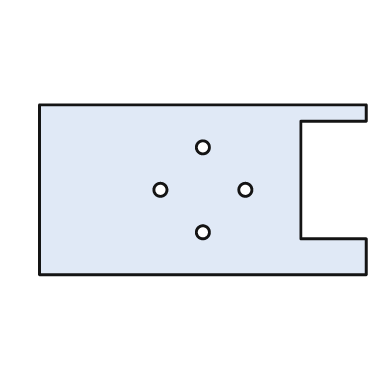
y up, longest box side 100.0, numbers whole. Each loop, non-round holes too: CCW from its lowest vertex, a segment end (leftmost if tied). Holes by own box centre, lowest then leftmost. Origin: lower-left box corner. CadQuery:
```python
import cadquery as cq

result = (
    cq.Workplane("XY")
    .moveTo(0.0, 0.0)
    .lineTo(100.0, 0.0)
    .lineTo(100.0, 11.0)
    .lineTo(80.0, 11.0)
    .lineTo(80.0, 47.0)
    .lineTo(100.0, 47.0)
    .lineTo(100.0, 52.0)
    .lineTo(0.0, 52.0)
    .close()
    .moveTo(50.0, 13.0)
    .circle(2.0)
    .moveTo(37.0, 26.0)
    .circle(2.0)
    .moveTo(63.0, 26.0)
    .circle(2.0)
    .moveTo(50.0, 39.0)
    .circle(2.0)
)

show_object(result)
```